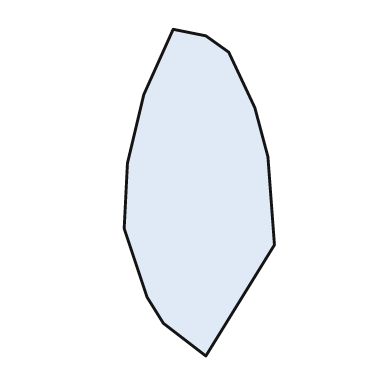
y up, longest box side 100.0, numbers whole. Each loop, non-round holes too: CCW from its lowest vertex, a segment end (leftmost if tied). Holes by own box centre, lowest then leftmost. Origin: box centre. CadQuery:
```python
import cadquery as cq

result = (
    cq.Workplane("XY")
    .moveTo(2.0, -50.0)
    .lineTo(23.0, -16.0)
    .lineTo(21.0, 11.0)
    .lineTo(17.0, 26.0)
    .lineTo(9.0, 43.0)
    .lineTo(2.0, 48.0)
    .lineTo(-8.0, 50.0)
    .lineTo(-17.0, 30.0)
    .lineTo(-22.0, 9.0)
    .lineTo(-23.0, -11.0)
    .lineTo(-16.0, -32.0)
    .lineTo(-11.0, -40.0)
    .close()
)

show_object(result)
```